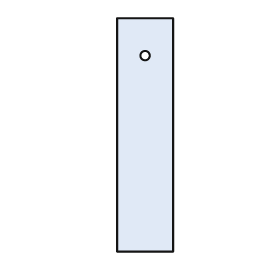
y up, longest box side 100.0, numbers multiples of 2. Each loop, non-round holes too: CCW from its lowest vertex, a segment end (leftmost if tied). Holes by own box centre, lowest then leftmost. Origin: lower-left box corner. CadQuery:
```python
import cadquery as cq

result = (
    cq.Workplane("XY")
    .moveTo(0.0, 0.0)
    .lineTo(24.0, 0.0)
    .lineTo(24.0, 100.0)
    .lineTo(0.0, 100.0)
    .close()
    .moveTo(12.0, 84.0)
    .circle(2.0)
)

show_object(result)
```